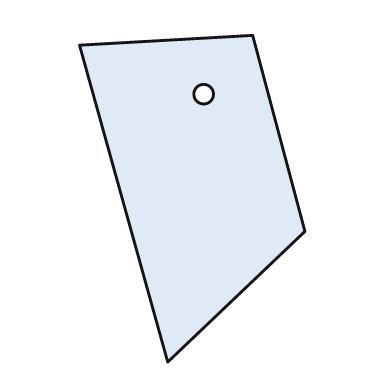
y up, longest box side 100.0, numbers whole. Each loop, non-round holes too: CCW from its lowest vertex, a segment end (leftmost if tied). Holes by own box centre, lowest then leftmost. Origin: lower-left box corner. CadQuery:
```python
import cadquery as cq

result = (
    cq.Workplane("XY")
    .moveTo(27.0, 0.0)
    .lineTo(69.0, 40.0)
    .lineTo(53.0, 100.0)
    .lineTo(0.0, 97.0)
    .close()
    .moveTo(38.0, 82.0)
    .circle(3.0)
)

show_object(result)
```